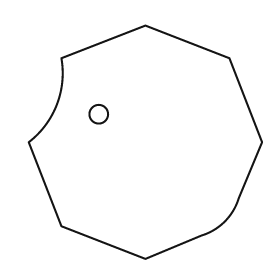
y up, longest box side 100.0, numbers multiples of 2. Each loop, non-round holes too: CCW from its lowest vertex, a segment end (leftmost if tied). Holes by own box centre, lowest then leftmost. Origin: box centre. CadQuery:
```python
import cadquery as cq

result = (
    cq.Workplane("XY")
    .moveTo(0.0, -50.0)
    .lineTo(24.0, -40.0)
    .threePointArc((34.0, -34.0), (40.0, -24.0))
    .lineTo(50.0, 0.0)
    .lineTo(36.0, 36.0)
    .lineTo(0.0, 50.0)
    .lineTo(-36.0, 36.0)
    .threePointArc((-38.0, 16.0), (-50.0, 0.0))
    .lineTo(-36.0, -36.0)
    .close()
    .moveTo(-20.0, 12.0)
    .circle(4.0)
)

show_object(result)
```